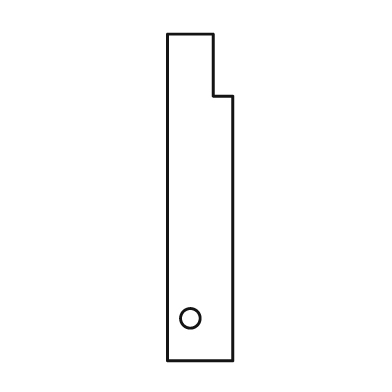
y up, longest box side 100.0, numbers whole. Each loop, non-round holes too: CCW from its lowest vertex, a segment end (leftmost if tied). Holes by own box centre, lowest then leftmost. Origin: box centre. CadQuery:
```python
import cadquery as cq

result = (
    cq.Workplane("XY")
    .moveTo(-10.0, -50.0)
    .lineTo(10.0, -50.0)
    .lineTo(10.0, 31.0)
    .lineTo(4.0, 31.0)
    .lineTo(4.0, 50.0)
    .lineTo(-10.0, 50.0)
    .close()
    .moveTo(-3.0, -37.0)
    .circle(3.0)
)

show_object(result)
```